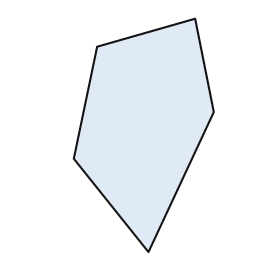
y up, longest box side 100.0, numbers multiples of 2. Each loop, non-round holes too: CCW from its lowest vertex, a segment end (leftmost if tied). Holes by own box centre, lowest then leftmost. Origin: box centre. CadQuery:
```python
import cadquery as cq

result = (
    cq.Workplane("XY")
    .moveTo(2.0, -50.0)
    .lineTo(30.0, 10.0)
    .lineTo(22.0, 50.0)
    .lineTo(-20.0, 38.0)
    .lineTo(-30.0, -10.0)
    .close()
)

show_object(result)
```